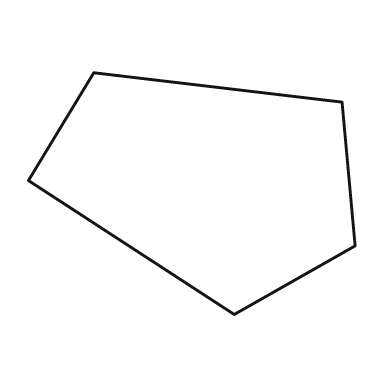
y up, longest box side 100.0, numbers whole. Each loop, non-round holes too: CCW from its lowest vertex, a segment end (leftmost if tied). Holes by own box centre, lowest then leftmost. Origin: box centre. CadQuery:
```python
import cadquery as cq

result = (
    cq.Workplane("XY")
    .moveTo(13.0, -37.0)
    .lineTo(50.0, -16.0)
    .lineTo(46.0, 28.0)
    .lineTo(-30.0, 37.0)
    .lineTo(-50.0, 4.0)
    .close()
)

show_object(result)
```